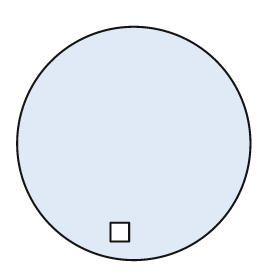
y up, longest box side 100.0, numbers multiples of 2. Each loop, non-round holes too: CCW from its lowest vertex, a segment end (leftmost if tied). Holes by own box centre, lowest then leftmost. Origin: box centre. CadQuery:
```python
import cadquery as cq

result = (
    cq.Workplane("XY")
    .moveTo(0.0, 0.0)
    .circle(50.0)
    .moveTo(-10.0, -42.0)
    .lineTo(-2.0, -42.0)
    .lineTo(-2.0, -34.0)
    .lineTo(-10.0, -34.0)
    .close()
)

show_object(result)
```